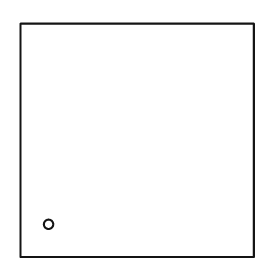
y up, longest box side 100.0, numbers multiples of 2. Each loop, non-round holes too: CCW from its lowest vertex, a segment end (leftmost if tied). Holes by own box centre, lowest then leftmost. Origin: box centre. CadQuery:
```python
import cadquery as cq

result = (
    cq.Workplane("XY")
    .moveTo(-50.0, -50.0)
    .lineTo(50.0, -50.0)
    .lineTo(50.0, 50.0)
    .lineTo(-50.0, 50.0)
    .close()
    .moveTo(-38.0, -36.0)
    .circle(2.0)
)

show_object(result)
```